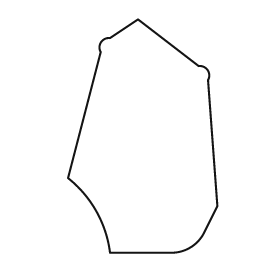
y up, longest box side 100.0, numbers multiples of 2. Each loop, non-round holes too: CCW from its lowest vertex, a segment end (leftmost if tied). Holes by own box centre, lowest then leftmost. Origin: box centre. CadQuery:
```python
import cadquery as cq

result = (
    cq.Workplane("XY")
    .moveTo(-14.0, -50.0)
    .lineTo(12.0, -50.0)
    .threePointArc((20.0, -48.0), (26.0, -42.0))
    .lineTo(32.0, -30.0)
    .lineTo(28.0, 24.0)
    .threePointArc((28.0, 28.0), (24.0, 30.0))
    .lineTo(-2.0, 50.0)
    .lineTo(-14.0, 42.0)
    .threePointArc((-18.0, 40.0), (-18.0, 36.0))
    .lineTo(-32.0, -18.0)
    .threePointArc((-20.0, -32.0), (-14.0, -50.0))
    .close()
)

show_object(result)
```